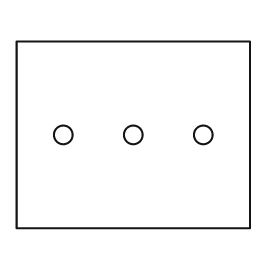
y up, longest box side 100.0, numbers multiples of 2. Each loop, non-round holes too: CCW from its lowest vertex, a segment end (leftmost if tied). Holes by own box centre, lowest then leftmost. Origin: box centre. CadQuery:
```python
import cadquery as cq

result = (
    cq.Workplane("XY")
    .moveTo(-50.0, -40.0)
    .lineTo(50.0, -40.0)
    .lineTo(50.0, 40.0)
    .lineTo(-50.0, 40.0)
    .close()
    .moveTo(-30.0, 0.0)
    .circle(4.0)
    .moveTo(0.0, 0.0)
    .circle(4.0)
    .moveTo(30.0, 0.0)
    .circle(4.0)
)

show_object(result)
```